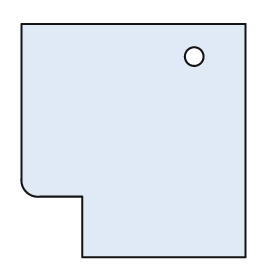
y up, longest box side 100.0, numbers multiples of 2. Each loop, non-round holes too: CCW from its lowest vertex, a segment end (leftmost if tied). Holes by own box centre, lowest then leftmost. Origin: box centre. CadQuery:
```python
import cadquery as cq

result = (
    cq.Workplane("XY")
    .moveTo(-22.0, -50.0)
    .lineTo(48.0, -50.0)
    .lineTo(48.0, 50.0)
    .lineTo(-48.0, 50.0)
    .lineTo(-48.0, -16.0)
    .threePointArc((-46.0, -22.0), (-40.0, -24.0))
    .lineTo(-22.0, -24.0)
    .close()
    .moveTo(26.0, 36.0)
    .circle(4.0)
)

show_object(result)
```